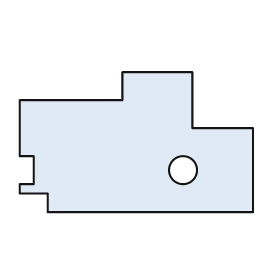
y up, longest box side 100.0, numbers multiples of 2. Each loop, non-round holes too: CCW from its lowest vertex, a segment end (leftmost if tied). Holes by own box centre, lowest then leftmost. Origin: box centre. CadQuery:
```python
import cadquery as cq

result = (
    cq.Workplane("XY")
    .moveTo(-38.0, -30.0)
    .lineTo(50.0, -30.0)
    .lineTo(50.0, 6.0)
    .lineTo(24.0, 6.0)
    .lineTo(24.0, 30.0)
    .lineTo(-6.0, 30.0)
    .lineTo(-6.0, 18.0)
    .lineTo(-50.0, 18.0)
    .lineTo(-50.0, -6.0)
    .lineTo(-44.0, -6.0)
    .lineTo(-44.0, -18.0)
    .lineTo(-50.0, -18.0)
    .lineTo(-50.0, -22.0)
    .lineTo(-38.0, -22.0)
    .close()
    .moveTo(20.0, -12.0)
    .circle(6.0)
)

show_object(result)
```